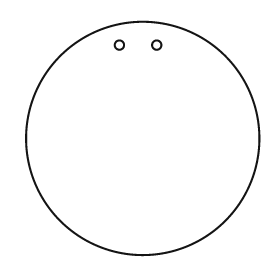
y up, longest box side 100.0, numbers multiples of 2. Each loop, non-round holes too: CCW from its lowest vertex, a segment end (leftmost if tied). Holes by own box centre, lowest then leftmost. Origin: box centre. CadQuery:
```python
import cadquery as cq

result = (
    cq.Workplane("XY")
    .moveTo(0.0, 0.0)
    .circle(50.0)
    .moveTo(-10.0, 40.0)
    .circle(2.0)
    .moveTo(6.0, 40.0)
    .circle(2.0)
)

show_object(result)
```